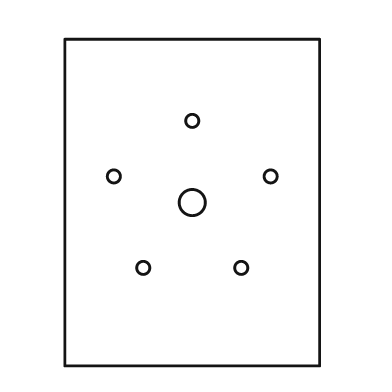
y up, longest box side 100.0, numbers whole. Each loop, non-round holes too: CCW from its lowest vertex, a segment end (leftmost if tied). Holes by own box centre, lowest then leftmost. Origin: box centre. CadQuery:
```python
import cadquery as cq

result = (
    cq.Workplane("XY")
    .moveTo(-39.0, -50.0)
    .lineTo(39.0, -50.0)
    .lineTo(39.0, 50.0)
    .lineTo(-39.0, 50.0)
    .close()
    .moveTo(-15.0, -20.0)
    .circle(2.0)
    .moveTo(15.0, -20.0)
    .circle(2.0)
    .moveTo(0.0, 0.0)
    .circle(4.0)
    .moveTo(-24.0, 8.0)
    .circle(2.0)
    .moveTo(24.0, 8.0)
    .circle(2.0)
    .moveTo(0.0, 25.0)
    .circle(2.0)
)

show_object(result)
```